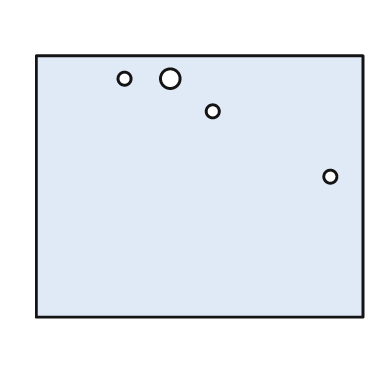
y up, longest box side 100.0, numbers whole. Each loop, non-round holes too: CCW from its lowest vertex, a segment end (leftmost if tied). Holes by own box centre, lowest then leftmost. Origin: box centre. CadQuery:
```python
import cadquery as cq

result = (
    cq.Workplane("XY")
    .moveTo(-50.0, -40.0)
    .lineTo(50.0, -40.0)
    .lineTo(50.0, 40.0)
    .lineTo(-50.0, 40.0)
    .close()
    .moveTo(40.0, 3.0)
    .circle(2.0)
    .moveTo(4.0, 23.0)
    .circle(2.0)
    .moveTo(-23.0, 33.0)
    .circle(2.0)
    .moveTo(-9.0, 33.0)
    .circle(3.0)
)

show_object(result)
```